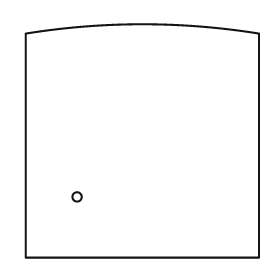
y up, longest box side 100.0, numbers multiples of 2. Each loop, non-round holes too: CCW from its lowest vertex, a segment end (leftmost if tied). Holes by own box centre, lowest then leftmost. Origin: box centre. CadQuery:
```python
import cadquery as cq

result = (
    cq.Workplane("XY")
    .moveTo(-50.0, -50.0)
    .lineTo(50.0, -50.0)
    .lineTo(50.0, 46.0)
    .threePointArc((0.0, 50.0), (-50.0, 46.0))
    .close()
    .moveTo(-28.0, -24.0)
    .circle(2.0)
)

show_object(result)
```